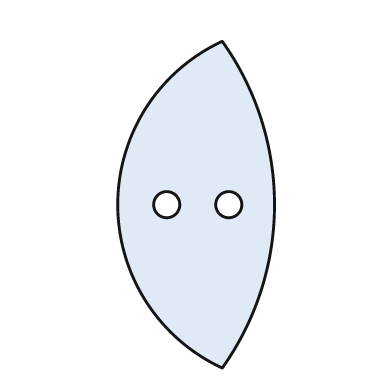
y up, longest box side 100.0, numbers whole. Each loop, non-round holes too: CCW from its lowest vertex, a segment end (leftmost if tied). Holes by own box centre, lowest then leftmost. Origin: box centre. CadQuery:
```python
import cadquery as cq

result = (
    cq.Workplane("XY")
    .moveTo(8.0, -50.0)
    .threePointArc((24.0, 0.0), (8.0, 50.0))
    .threePointArc((-24.0, 0.0), (8.0, -50.0))
    .close()
    .moveTo(-9.0, 0.0)
    .circle(4.0)
    .moveTo(10.0, 0.0)
    .circle(4.0)
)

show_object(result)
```